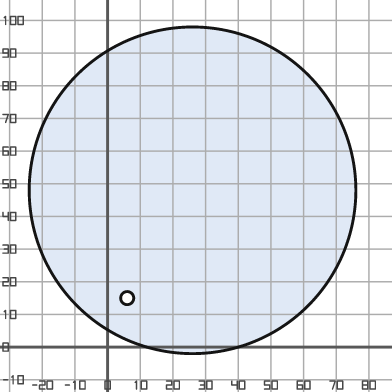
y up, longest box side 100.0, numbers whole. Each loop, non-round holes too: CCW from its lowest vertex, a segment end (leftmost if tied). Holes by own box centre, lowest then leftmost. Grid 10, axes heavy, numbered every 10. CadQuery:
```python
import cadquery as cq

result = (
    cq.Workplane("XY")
    .moveTo(26.0, 48.0)
    .circle(50.0)
    .moveTo(6.0, 15.0)
    .circle(2.0)
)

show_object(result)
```